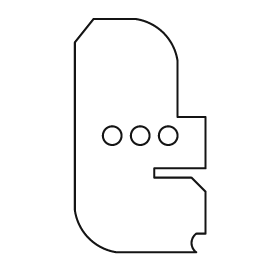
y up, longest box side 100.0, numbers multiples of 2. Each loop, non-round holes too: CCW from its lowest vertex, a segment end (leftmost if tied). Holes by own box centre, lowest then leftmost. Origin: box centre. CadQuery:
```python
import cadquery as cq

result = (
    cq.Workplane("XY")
    .moveTo(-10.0, -50.0)
    .lineTo(24.0, -50.0)
    .threePointArc((22.0, -46.0), (24.0, -42.0))
    .lineTo(28.0, -42.0)
    .lineTo(28.0, -24.0)
    .lineTo(22.0, -18.0)
    .lineTo(6.0, -18.0)
    .lineTo(6.0, -14.0)
    .lineTo(28.0, -14.0)
    .lineTo(28.0, 8.0)
    .lineTo(16.0, 8.0)
    .lineTo(16.0, 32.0)
    .threePointArc((10.0, 44.0), (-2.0, 50.0))
    .lineTo(-20.0, 50.0)
    .lineTo(-28.0, 40.0)
    .lineTo(-28.0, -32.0)
    .threePointArc((-22.0, -44.0), (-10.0, -50.0))
    .close()
    .moveTo(-12.0, 0.0)
    .circle(4.0)
    .moveTo(0.0, 0.0)
    .circle(4.0)
    .moveTo(12.0, 0.0)
    .circle(4.0)
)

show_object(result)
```